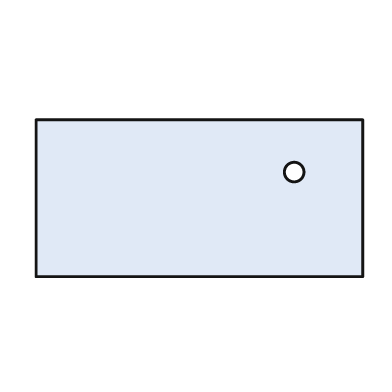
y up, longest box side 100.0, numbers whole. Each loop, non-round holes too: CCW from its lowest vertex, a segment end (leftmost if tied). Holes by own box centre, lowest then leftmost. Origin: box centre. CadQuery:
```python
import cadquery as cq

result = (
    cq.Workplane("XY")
    .moveTo(-50.0, -24.0)
    .lineTo(50.0, -24.0)
    .lineTo(50.0, 24.0)
    .lineTo(-50.0, 24.0)
    .close()
    .moveTo(29.0, 8.0)
    .circle(3.0)
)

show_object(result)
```